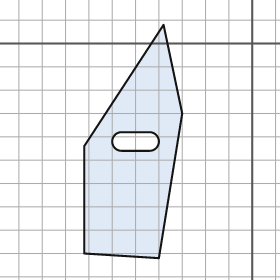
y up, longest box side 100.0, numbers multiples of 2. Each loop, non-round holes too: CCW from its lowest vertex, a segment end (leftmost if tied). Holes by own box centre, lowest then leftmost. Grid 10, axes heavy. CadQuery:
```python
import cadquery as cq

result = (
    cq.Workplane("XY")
    .moveTo(-40.0, -92.0)
    .lineTo(-30.0, -30.0)
    .lineTo(-38.0, 8.0)
    .lineTo(-72.0, -44.0)
    .lineTo(-72.0, -90.0)
    .close()
    .moveTo(-56.0, -46.0)
    .lineTo(-44.0, -46.0)
    .threePointArc((-40.0, -42.0), (-44.0, -38.0))
    .lineTo(-56.0, -38.0)
    .threePointArc((-60.0, -42.0), (-56.0, -46.0))
    .close()
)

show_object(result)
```